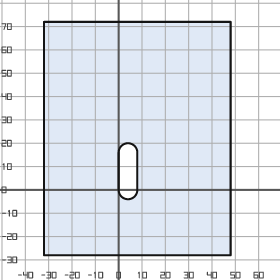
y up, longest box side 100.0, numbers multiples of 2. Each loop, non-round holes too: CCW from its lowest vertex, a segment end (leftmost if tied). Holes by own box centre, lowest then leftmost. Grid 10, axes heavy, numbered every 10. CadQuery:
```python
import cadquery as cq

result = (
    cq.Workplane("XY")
    .moveTo(-32.0, -28.0)
    .lineTo(48.0, -28.0)
    .lineTo(48.0, 72.0)
    .lineTo(-32.0, 72.0)
    .close()
    .moveTo(0.0, 0.0)
    .threePointArc((4.0, -4.0), (8.0, 0.0))
    .lineTo(8.0, 16.0)
    .threePointArc((4.0, 20.0), (0.0, 16.0))
    .close()
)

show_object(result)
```